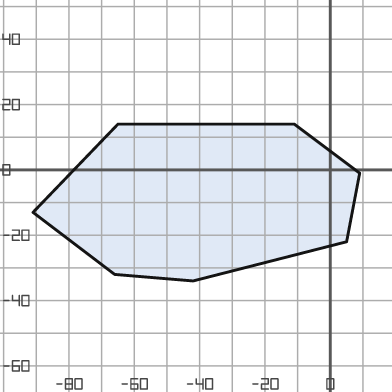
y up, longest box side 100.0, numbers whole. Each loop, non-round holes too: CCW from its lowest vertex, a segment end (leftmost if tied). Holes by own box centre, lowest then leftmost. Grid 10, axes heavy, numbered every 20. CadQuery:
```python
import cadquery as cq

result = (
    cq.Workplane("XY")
    .moveTo(-42.0, -34.0)
    .lineTo(5.0, -22.0)
    .lineTo(9.0, -1.0)
    .lineTo(-11.0, 14.0)
    .lineTo(-65.0, 14.0)
    .lineTo(-91.0, -13.0)
    .lineTo(-66.0, -32.0)
    .close()
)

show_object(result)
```